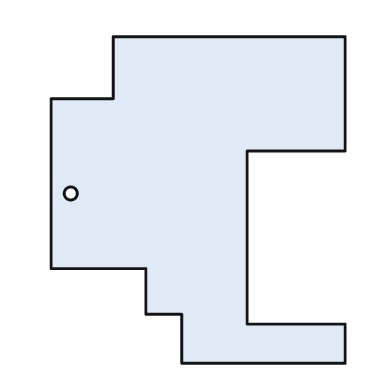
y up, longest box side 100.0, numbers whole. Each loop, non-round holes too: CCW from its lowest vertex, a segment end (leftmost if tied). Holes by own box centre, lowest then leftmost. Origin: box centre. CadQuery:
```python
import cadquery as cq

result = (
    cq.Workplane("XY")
    .moveTo(-5.0, -50.0)
    .lineTo(45.0, -50.0)
    .lineTo(45.0, -38.0)
    .lineTo(15.0, -38.0)
    .lineTo(15.0, 15.0)
    .lineTo(45.0, 15.0)
    .lineTo(45.0, 50.0)
    .lineTo(-26.0, 50.0)
    .lineTo(-26.0, 31.0)
    .lineTo(-45.0, 31.0)
    .lineTo(-45.0, -21.0)
    .lineTo(-16.0, -21.0)
    .lineTo(-16.0, -35.0)
    .lineTo(-5.0, -35.0)
    .close()
    .moveTo(-39.0, 2.0)
    .circle(2.0)
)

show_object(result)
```